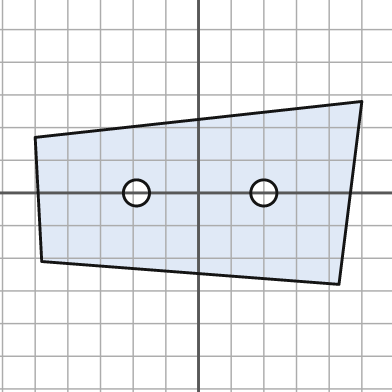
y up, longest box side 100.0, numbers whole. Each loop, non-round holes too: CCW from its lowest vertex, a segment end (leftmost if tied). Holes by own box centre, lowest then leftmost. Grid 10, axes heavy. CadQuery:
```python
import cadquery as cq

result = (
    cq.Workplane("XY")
    .moveTo(43.0, -28.0)
    .lineTo(50.0, 28.0)
    .lineTo(-50.0, 17.0)
    .lineTo(-48.0, -21.0)
    .close()
    .moveTo(-19.0, 0.0)
    .circle(4.0)
    .moveTo(20.0, 0.0)
    .circle(4.0)
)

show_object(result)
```